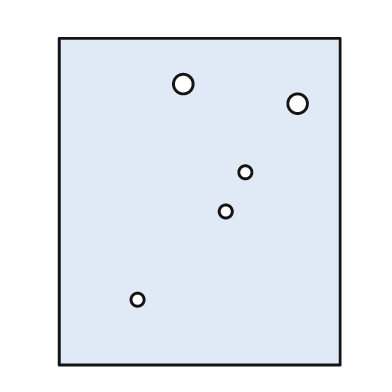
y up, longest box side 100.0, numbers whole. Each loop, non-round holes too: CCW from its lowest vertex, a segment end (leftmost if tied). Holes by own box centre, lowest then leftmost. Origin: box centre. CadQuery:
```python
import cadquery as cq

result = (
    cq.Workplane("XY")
    .moveTo(-43.0, -50.0)
    .lineTo(43.0, -50.0)
    .lineTo(43.0, 50.0)
    .lineTo(-43.0, 50.0)
    .close()
    .moveTo(-19.0, -30.0)
    .circle(2.0)
    .moveTo(8.0, -3.0)
    .circle(2.0)
    .moveTo(14.0, 9.0)
    .circle(2.0)
    .moveTo(30.0, 30.0)
    .circle(3.0)
    .moveTo(-5.0, 36.0)
    .circle(3.0)
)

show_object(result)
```